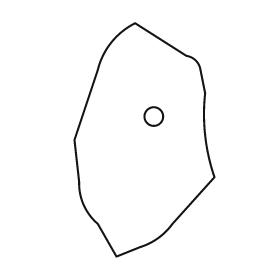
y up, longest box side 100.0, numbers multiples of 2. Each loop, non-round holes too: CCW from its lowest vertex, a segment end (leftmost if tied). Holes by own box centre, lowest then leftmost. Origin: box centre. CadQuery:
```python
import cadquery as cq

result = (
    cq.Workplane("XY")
    .moveTo(-12.0, -50.0)
    .lineTo(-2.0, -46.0)
    .threePointArc((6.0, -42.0), (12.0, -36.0))
    .lineTo(30.0, -16.0)
    .threePointArc((26.0, 2.0), (26.0, 20.0))
    .lineTo(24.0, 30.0)
    .threePointArc((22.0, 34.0), (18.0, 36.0))
    .lineTo(-4.0, 50.0)
    .threePointArc((-14.0, 42.0), (-20.0, 30.0))
    .lineTo(-30.0, 0.0)
    .lineTo(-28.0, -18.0)
    .threePointArc((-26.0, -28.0), (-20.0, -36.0))
    .close()
    .moveTo(4.0, 10.0)
    .circle(4.0)
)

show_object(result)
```